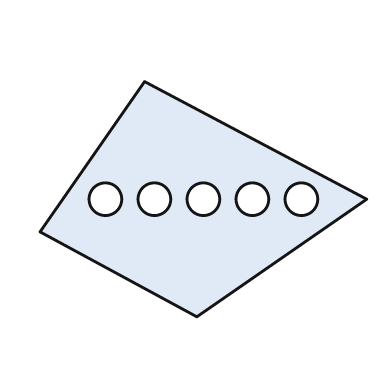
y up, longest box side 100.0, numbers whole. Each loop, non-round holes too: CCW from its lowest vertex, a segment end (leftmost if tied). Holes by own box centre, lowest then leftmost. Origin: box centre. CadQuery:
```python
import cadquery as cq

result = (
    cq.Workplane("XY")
    .moveTo(-2.0, -36.0)
    .lineTo(50.0, 0.0)
    .lineTo(-18.0, 36.0)
    .lineTo(-50.0, -10.0)
    .close()
    .moveTo(-30.0, 0.0)
    .circle(5.0)
    .moveTo(-15.0, 0.0)
    .circle(5.0)
    .moveTo(0.0, 0.0)
    .circle(5.0)
    .moveTo(15.0, 0.0)
    .circle(5.0)
    .moveTo(30.0, 0.0)
    .circle(5.0)
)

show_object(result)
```